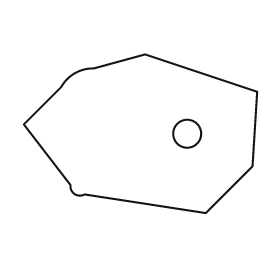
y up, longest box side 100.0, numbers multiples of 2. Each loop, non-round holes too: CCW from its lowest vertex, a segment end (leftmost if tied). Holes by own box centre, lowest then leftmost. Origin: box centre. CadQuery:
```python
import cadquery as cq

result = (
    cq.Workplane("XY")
    .moveTo(28.0, -34.0)
    .lineTo(48.0, -14.0)
    .lineTo(50.0, 18.0)
    .lineTo(2.0, 34.0)
    .lineTo(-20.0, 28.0)
    .threePointArc((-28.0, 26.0), (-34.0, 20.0))
    .lineTo(-50.0, 4.0)
    .lineTo(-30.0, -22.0)
    .threePointArc((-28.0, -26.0), (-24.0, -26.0))
    .close()
    .moveTo(20.0, 0.0)
    .circle(6.0)
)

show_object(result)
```